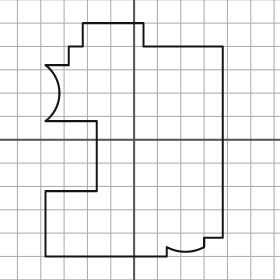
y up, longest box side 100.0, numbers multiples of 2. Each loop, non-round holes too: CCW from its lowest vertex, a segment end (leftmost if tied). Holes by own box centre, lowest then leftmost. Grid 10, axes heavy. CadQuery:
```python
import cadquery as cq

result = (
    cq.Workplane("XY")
    .moveTo(-38.0, -50.0)
    .lineTo(14.0, -50.0)
    .lineTo(14.0, -46.0)
    .threePointArc((22.0, -48.0), (30.0, -46.0))
    .lineTo(30.0, -42.0)
    .lineTo(38.0, -42.0)
    .lineTo(38.0, 40.0)
    .lineTo(4.0, 40.0)
    .lineTo(4.0, 50.0)
    .lineTo(-22.0, 50.0)
    .lineTo(-22.0, 40.0)
    .lineTo(-28.0, 40.0)
    .lineTo(-28.0, 32.0)
    .lineTo(-38.0, 32.0)
    .threePointArc((-32.0, 20.0), (-38.0, 8.0))
    .lineTo(-16.0, 8.0)
    .lineTo(-16.0, -22.0)
    .lineTo(-38.0, -22.0)
    .close()
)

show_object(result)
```